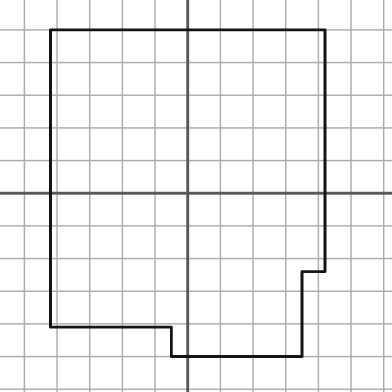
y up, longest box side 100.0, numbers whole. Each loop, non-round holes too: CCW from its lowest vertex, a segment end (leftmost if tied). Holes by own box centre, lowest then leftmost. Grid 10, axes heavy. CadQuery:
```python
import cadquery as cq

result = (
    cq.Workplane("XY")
    .moveTo(-5.0, -50.0)
    .lineTo(35.0, -50.0)
    .lineTo(35.0, -24.0)
    .lineTo(42.0, -24.0)
    .lineTo(42.0, 50.0)
    .lineTo(-42.0, 50.0)
    .lineTo(-42.0, -41.0)
    .lineTo(-5.0, -41.0)
    .close()
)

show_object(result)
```